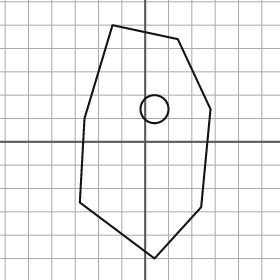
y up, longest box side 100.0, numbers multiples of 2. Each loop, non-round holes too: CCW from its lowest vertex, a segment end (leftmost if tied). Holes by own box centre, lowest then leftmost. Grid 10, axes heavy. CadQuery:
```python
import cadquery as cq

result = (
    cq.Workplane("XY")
    .moveTo(4.0, -50.0)
    .lineTo(24.0, -28.0)
    .lineTo(28.0, 14.0)
    .lineTo(14.0, 44.0)
    .lineTo(-14.0, 50.0)
    .lineTo(-26.0, 10.0)
    .lineTo(-28.0, -26.0)
    .close()
    .moveTo(4.0, 14.0)
    .circle(6.0)
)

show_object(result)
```